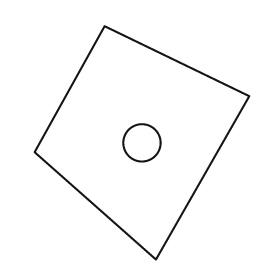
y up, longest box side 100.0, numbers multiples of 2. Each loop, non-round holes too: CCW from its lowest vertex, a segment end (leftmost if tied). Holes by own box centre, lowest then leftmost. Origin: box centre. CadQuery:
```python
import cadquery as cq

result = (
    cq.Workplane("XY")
    .moveTo(6.0, -50.0)
    .lineTo(46.0, 20.0)
    .lineTo(-16.0, 50.0)
    .lineTo(-46.0, -4.0)
    .close()
    .moveTo(0.0, 0.0)
    .circle(8.0)
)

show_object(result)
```